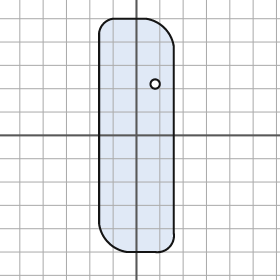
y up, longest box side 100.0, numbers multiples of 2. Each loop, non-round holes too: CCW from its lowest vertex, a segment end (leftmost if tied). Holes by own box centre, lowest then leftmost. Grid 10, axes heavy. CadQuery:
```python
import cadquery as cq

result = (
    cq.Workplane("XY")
    .moveTo(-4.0, -50.0)
    .lineTo(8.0, -50.0)
    .threePointArc((14.0, -48.0), (16.0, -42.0))
    .lineTo(16.0, 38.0)
    .threePointArc((12.0, 46.0), (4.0, 50.0))
    .lineTo(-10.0, 50.0)
    .threePointArc((-14.0, 48.0), (-16.0, 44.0))
    .lineTo(-16.0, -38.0)
    .threePointArc((-12.0, -46.0), (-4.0, -50.0))
    .close()
    .moveTo(8.0, 22.0)
    .circle(2.0)
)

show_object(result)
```